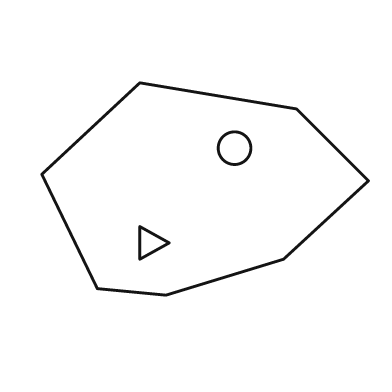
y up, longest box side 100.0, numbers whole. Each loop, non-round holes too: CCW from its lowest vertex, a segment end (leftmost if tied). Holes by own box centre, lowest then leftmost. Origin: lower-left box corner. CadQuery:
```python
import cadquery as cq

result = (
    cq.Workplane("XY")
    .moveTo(38.0, 0.0)
    .lineTo(74.0, 11.0)
    .lineTo(100.0, 35.0)
    .lineTo(78.0, 57.0)
    .lineTo(30.0, 65.0)
    .lineTo(0.0, 37.0)
    .lineTo(17.0, 2.0)
    .close()
    .moveTo(30.0, 11.0)
    .lineTo(39.0, 16.0)
    .lineTo(30.0, 21.0)
    .close()
    .moveTo(59.0, 45.0)
    .circle(5.0)
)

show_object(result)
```